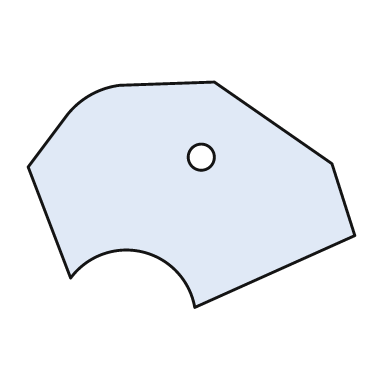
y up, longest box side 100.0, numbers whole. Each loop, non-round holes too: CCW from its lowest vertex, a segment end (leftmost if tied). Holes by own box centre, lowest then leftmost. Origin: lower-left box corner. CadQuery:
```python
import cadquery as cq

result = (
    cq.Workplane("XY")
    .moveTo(51.0, 0.0)
    .lineTo(100.0, 22.0)
    .lineTo(93.0, 44.0)
    .lineTo(57.0, 69.0)
    .lineTo(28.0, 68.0)
    .threePointArc((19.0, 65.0), (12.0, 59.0))
    .lineTo(0.0, 43.0)
    .lineTo(13.0, 9.0)
    .threePointArc((35.0, 17.0), (51.0, 0.0))
    .close()
    .moveTo(53.0, 46.0)
    .circle(4.0)
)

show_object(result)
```